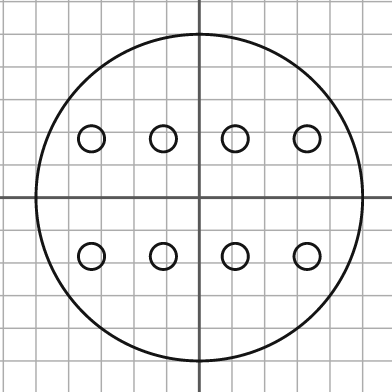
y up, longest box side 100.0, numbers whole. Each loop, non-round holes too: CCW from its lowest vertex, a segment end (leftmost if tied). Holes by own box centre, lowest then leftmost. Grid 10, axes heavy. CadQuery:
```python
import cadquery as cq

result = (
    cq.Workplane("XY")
    .moveTo(0.0, 0.0)
    .circle(50.0)
    .moveTo(-33.0, -18.0)
    .circle(4.0)
    .moveTo(-11.0, -18.0)
    .circle(4.0)
    .moveTo(11.0, -18.0)
    .circle(4.0)
    .moveTo(33.0, -18.0)
    .circle(4.0)
    .moveTo(-33.0, 18.0)
    .circle(4.0)
    .moveTo(-11.0, 18.0)
    .circle(4.0)
    .moveTo(11.0, 18.0)
    .circle(4.0)
    .moveTo(33.0, 18.0)
    .circle(4.0)
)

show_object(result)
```